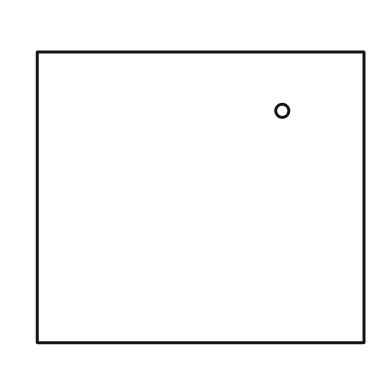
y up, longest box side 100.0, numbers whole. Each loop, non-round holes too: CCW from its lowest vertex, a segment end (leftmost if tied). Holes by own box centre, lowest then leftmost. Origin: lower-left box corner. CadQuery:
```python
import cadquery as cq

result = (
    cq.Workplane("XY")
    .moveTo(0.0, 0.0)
    .lineTo(100.0, 0.0)
    .lineTo(100.0, 89.0)
    .lineTo(0.0, 89.0)
    .close()
    .moveTo(75.0, 71.0)
    .circle(2.0)
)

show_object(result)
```